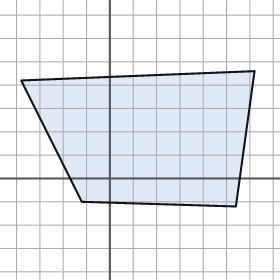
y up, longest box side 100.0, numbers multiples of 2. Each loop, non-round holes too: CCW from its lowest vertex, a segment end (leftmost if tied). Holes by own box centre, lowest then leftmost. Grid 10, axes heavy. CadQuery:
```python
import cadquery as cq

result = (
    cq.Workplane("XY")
    .moveTo(54.0, -12.0)
    .lineTo(62.0, 46.0)
    .lineTo(-38.0, 42.0)
    .lineTo(-12.0, -10.0)
    .close()
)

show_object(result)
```